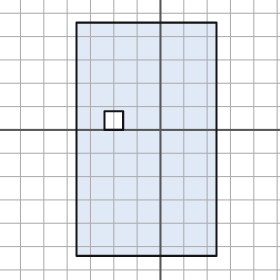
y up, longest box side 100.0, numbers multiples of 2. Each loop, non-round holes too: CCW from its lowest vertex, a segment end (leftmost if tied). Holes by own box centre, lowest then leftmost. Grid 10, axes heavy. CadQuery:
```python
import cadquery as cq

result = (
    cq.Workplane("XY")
    .moveTo(-36.0, -54.0)
    .lineTo(24.0, -54.0)
    .lineTo(24.0, 46.0)
    .lineTo(-36.0, 46.0)
    .close()
    .moveTo(-24.0, 0.0)
    .lineTo(-16.0, 0.0)
    .lineTo(-16.0, 8.0)
    .lineTo(-24.0, 8.0)
    .close()
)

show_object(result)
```